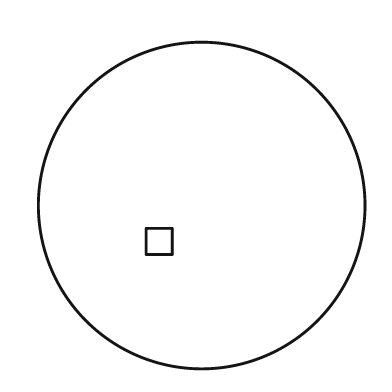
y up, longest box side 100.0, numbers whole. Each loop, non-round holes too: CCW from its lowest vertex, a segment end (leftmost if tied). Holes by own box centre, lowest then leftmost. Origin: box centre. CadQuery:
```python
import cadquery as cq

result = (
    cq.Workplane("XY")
    .moveTo(0.0, 0.0)
    .circle(50.0)
    .moveTo(-17.0, -15.0)
    .lineTo(-9.0, -15.0)
    .lineTo(-9.0, -7.0)
    .lineTo(-17.0, -7.0)
    .close()
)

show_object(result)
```